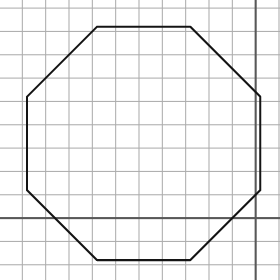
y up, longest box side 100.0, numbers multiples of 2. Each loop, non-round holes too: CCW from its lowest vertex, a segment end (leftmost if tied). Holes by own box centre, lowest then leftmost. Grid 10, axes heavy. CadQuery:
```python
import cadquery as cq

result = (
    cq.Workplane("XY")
    .moveTo(-68.0, -18.0)
    .lineTo(-28.0, -18.0)
    .lineTo(2.0, 12.0)
    .lineTo(2.0, 52.0)
    .lineTo(-28.0, 82.0)
    .lineTo(-68.0, 82.0)
    .lineTo(-98.0, 52.0)
    .lineTo(-98.0, 12.0)
    .close()
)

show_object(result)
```